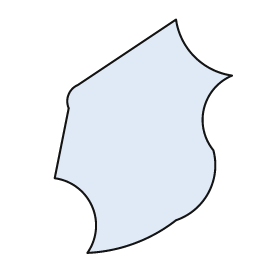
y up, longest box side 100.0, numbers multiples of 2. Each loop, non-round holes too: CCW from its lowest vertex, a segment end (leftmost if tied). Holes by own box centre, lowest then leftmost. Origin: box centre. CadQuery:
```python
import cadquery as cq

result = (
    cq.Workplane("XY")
    .moveTo(-24.0, -50.0)
    .threePointArc((-4.0, -46.0), (14.0, -36.0))
    .threePointArc((28.0, -24.0), (30.0, -6.0))
    .threePointArc((26.0, 12.0), (38.0, 26.0))
    .threePointArc((22.0, 34.0), (14.0, 50.0))
    .lineTo(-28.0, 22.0)
    .threePointArc((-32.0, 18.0), (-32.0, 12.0))
    .lineTo(-38.0, -18.0)
    .threePointArc((-22.0, -30.0), (-24.0, -50.0))
    .close()
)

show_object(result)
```